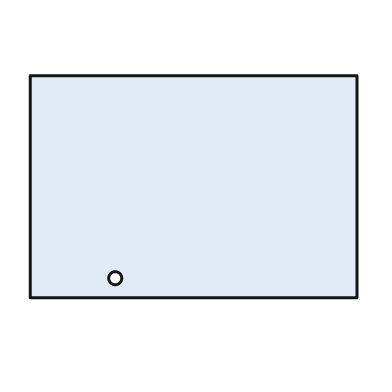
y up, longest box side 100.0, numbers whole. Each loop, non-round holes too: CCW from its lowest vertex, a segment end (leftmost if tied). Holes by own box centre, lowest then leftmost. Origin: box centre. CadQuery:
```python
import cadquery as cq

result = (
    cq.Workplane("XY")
    .moveTo(-50.0, -34.0)
    .lineTo(50.0, -34.0)
    .lineTo(50.0, 34.0)
    .lineTo(-50.0, 34.0)
    .close()
    .moveTo(-24.0, -28.0)
    .circle(2.0)
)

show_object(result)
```